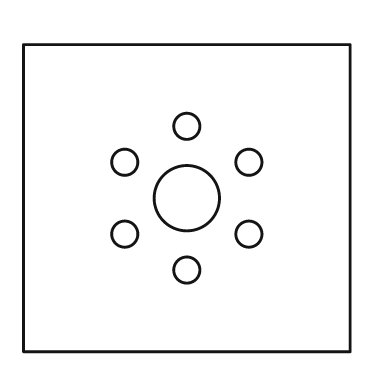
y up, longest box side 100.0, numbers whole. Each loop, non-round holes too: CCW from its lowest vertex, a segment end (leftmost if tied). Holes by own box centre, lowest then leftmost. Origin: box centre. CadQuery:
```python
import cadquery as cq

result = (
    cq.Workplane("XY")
    .moveTo(-50.0, -47.0)
    .lineTo(50.0, -47.0)
    .lineTo(50.0, 47.0)
    .lineTo(-50.0, 47.0)
    .close()
    .moveTo(0.0, -22.0)
    .circle(4.0)
    .moveTo(-19.0, -11.0)
    .circle(4.0)
    .moveTo(19.0, -11.0)
    .circle(4.0)
    .moveTo(0.0, 0.0)
    .circle(10.0)
    .moveTo(-19.0, 11.0)
    .circle(4.0)
    .moveTo(19.0, 11.0)
    .circle(4.0)
    .moveTo(0.0, 22.0)
    .circle(4.0)
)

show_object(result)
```